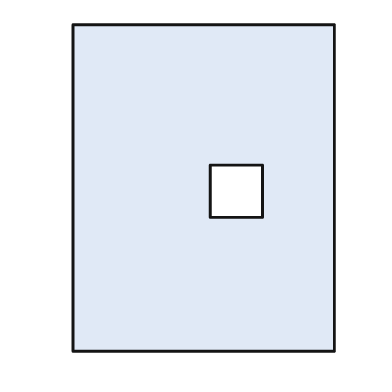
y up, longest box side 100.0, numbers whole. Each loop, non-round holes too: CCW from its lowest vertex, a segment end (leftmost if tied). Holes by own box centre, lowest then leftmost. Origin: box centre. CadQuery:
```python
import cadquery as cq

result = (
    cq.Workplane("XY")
    .moveTo(-40.0, -50.0)
    .lineTo(40.0, -50.0)
    .lineTo(40.0, 50.0)
    .lineTo(-40.0, 50.0)
    .close()
    .moveTo(2.0, -9.0)
    .lineTo(18.0, -9.0)
    .lineTo(18.0, 7.0)
    .lineTo(2.0, 7.0)
    .close()
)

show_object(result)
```